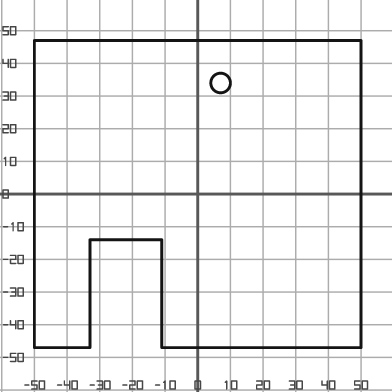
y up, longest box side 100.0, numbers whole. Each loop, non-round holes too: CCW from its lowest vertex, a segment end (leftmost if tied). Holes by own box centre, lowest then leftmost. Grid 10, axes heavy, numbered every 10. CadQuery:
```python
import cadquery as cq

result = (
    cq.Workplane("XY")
    .moveTo(-50.0, -47.0)
    .lineTo(-33.0, -47.0)
    .lineTo(-33.0, -14.0)
    .lineTo(-11.0, -14.0)
    .lineTo(-11.0, -47.0)
    .lineTo(50.0, -47.0)
    .lineTo(50.0, 47.0)
    .lineTo(-50.0, 47.0)
    .close()
    .moveTo(7.0, 34.0)
    .circle(3.0)
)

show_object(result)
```